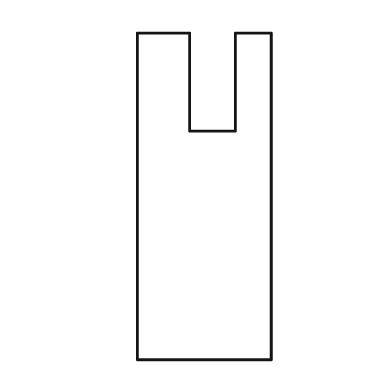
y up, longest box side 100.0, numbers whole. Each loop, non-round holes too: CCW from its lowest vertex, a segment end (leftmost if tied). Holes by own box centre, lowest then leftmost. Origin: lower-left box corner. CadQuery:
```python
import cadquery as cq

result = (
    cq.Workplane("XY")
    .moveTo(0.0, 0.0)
    .lineTo(41.0, 0.0)
    .lineTo(41.0, 100.0)
    .lineTo(30.0, 100.0)
    .lineTo(30.0, 70.0)
    .lineTo(16.0, 70.0)
    .lineTo(16.0, 100.0)
    .lineTo(0.0, 100.0)
    .close()
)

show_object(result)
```